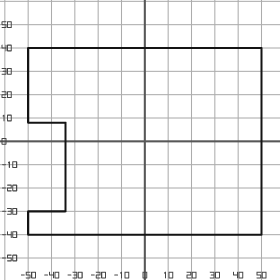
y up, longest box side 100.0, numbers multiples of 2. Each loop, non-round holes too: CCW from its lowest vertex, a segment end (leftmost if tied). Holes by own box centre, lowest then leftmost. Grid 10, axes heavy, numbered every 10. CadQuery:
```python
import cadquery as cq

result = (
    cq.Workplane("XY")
    .moveTo(-50.0, -40.0)
    .lineTo(50.0, -40.0)
    .lineTo(50.0, 40.0)
    .lineTo(-50.0, 40.0)
    .lineTo(-50.0, 8.0)
    .lineTo(-34.0, 8.0)
    .lineTo(-34.0, -30.0)
    .lineTo(-50.0, -30.0)
    .close()
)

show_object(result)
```